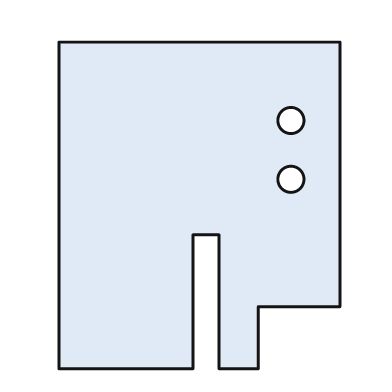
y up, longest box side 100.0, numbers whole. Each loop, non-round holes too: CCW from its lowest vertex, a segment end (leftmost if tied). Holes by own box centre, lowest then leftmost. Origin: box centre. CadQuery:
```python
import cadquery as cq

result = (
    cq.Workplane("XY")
    .moveTo(-43.0, -50.0)
    .lineTo(-2.0, -50.0)
    .lineTo(-2.0, -9.0)
    .lineTo(6.0, -9.0)
    .lineTo(6.0, -50.0)
    .lineTo(18.0, -50.0)
    .lineTo(18.0, -31.0)
    .lineTo(43.0, -31.0)
    .lineTo(43.0, 50.0)
    .lineTo(-43.0, 50.0)
    .close()
    .moveTo(28.0, 8.0)
    .circle(4.0)
    .moveTo(28.0, 26.0)
    .circle(4.0)
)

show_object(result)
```